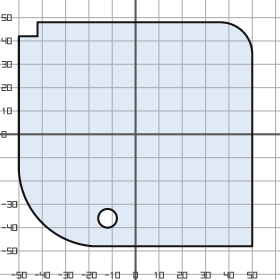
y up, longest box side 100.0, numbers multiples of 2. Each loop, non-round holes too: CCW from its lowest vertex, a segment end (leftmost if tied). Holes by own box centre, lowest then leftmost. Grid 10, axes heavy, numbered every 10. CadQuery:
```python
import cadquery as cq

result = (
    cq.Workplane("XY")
    .moveTo(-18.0, -48.0)
    .lineTo(50.0, -48.0)
    .lineTo(50.0, 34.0)
    .threePointArc((46.0, 44.0), (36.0, 48.0))
    .lineTo(-42.0, 48.0)
    .lineTo(-42.0, 42.0)
    .lineTo(-50.0, 42.0)
    .lineTo(-50.0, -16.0)
    .threePointArc((-40.0, -38.0), (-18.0, -48.0))
    .close()
    .moveTo(-12.0, -36.0)
    .circle(4.0)
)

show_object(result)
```